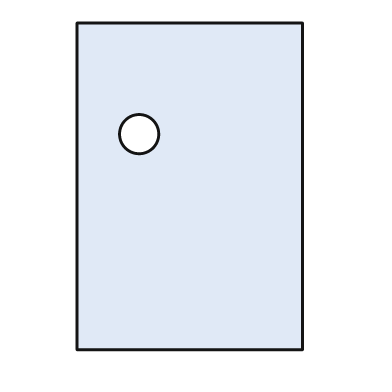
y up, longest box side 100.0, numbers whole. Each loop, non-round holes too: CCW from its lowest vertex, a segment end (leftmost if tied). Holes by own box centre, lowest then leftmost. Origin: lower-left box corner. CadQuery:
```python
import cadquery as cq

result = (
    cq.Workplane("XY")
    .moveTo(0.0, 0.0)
    .lineTo(69.0, 0.0)
    .lineTo(69.0, 100.0)
    .lineTo(0.0, 100.0)
    .close()
    .moveTo(19.0, 66.0)
    .circle(6.0)
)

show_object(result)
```